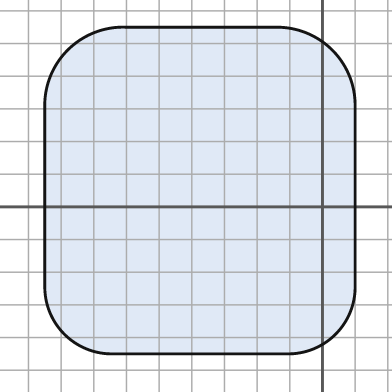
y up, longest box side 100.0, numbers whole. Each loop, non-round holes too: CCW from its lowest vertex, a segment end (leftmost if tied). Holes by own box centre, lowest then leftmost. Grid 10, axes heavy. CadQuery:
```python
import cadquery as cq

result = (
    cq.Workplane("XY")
    .moveTo(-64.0, -45.0)
    .lineTo(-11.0, -45.0)
    .threePointArc((4.0, -39.0), (10.0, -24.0))
    .lineTo(10.0, 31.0)
    .threePointArc((3.0, 48.0), (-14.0, 55.0))
    .lineTo(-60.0, 55.0)
    .threePointArc((-78.0, 48.0), (-85.0, 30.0))
    .lineTo(-85.0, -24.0)
    .threePointArc((-79.0, -39.0), (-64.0, -45.0))
    .close()
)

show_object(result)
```